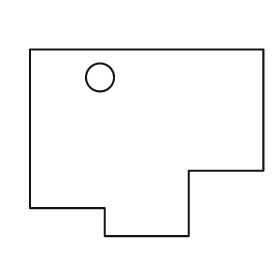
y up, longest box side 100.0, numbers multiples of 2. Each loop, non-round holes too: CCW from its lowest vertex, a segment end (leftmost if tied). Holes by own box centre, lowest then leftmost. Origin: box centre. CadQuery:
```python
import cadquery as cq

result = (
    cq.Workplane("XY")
    .moveTo(-18.0, -40.0)
    .lineTo(18.0, -40.0)
    .lineTo(18.0, -12.0)
    .lineTo(50.0, -12.0)
    .lineTo(50.0, 40.0)
    .lineTo(-50.0, 40.0)
    .lineTo(-50.0, -28.0)
    .lineTo(-18.0, -28.0)
    .close()
    .moveTo(-20.0, 28.0)
    .circle(6.0)
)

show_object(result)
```